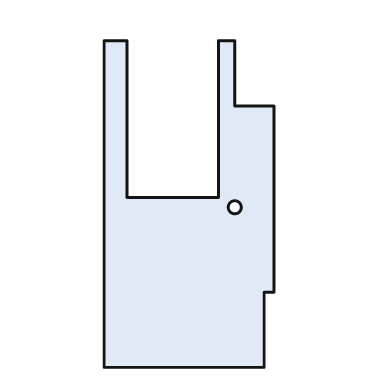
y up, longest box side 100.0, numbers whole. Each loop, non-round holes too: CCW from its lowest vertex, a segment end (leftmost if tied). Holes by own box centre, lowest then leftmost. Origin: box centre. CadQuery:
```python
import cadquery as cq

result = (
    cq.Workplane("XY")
    .moveTo(-26.0, -50.0)
    .lineTo(23.0, -50.0)
    .lineTo(23.0, -27.0)
    .lineTo(26.0, -27.0)
    .lineTo(26.0, 30.0)
    .lineTo(14.0, 30.0)
    .lineTo(14.0, 50.0)
    .lineTo(9.0, 50.0)
    .lineTo(9.0, 2.0)
    .lineTo(-19.0, 2.0)
    .lineTo(-19.0, 50.0)
    .lineTo(-26.0, 50.0)
    .close()
    .moveTo(14.0, -1.0)
    .circle(2.0)
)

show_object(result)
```